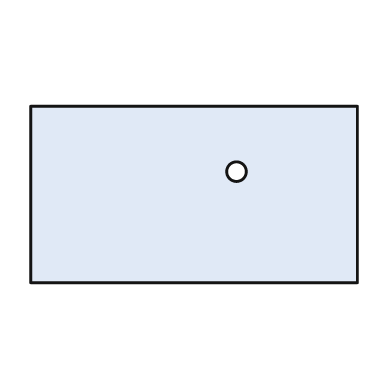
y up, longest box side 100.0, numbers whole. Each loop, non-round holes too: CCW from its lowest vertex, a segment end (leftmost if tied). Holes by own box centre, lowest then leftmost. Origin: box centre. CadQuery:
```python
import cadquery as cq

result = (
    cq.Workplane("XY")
    .moveTo(-50.0, -27.0)
    .lineTo(50.0, -27.0)
    .lineTo(50.0, 27.0)
    .lineTo(-50.0, 27.0)
    .close()
    .moveTo(13.0, 7.0)
    .circle(3.0)
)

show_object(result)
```